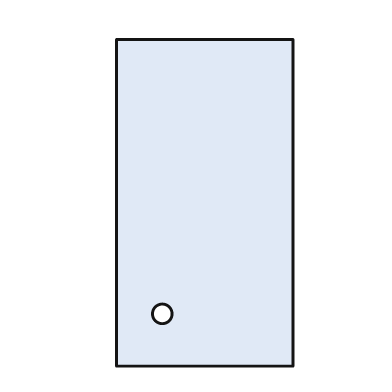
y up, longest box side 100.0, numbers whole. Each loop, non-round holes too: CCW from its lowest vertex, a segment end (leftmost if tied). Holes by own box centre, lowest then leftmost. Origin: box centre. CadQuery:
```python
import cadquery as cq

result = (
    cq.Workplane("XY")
    .moveTo(-27.0, -50.0)
    .lineTo(27.0, -50.0)
    .lineTo(27.0, 50.0)
    .lineTo(-27.0, 50.0)
    .close()
    .moveTo(-13.0, -34.0)
    .circle(3.0)
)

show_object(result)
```